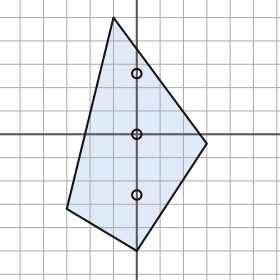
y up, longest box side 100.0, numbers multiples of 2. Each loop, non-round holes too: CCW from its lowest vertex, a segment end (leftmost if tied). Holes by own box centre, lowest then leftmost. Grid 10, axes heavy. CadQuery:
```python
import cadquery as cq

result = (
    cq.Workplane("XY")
    .moveTo(0.0, -50.0)
    .lineTo(30.0, -4.0)
    .lineTo(-10.0, 50.0)
    .lineTo(-30.0, -32.0)
    .close()
    .moveTo(0.0, -26.0)
    .circle(2.0)
    .moveTo(0.0, 0.0)
    .circle(2.0)
    .moveTo(0.0, 26.0)
    .circle(2.0)
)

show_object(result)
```